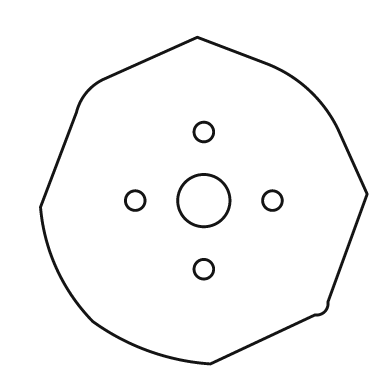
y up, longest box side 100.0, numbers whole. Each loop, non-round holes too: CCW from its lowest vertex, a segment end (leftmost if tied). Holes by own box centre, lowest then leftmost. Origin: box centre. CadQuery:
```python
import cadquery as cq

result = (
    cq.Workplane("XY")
    .moveTo(2.0, -50.0)
    .lineTo(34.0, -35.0)
    .threePointArc((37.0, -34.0), (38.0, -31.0))
    .lineTo(50.0, 2.0)
    .lineTo(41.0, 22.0)
    .threePointArc((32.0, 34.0), (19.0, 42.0))
    .lineTo(-2.0, 50.0)
    .lineTo(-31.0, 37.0)
    .threePointArc((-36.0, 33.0), (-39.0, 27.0))
    .lineTo(-50.0, -2.0)
    .threePointArc((-45.0, -21.0), (-34.0, -37.0))
    .threePointArc((-17.0, -46.0), (2.0, -50.0))
    .close()
    .moveTo(0.0, -21.0)
    .circle(3.0)
    .moveTo(-21.0, 0.0)
    .circle(3.0)
    .moveTo(0.0, 0.0)
    .circle(8.0)
    .moveTo(21.0, 0.0)
    .circle(3.0)
    .moveTo(0.0, 21.0)
    .circle(3.0)
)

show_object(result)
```